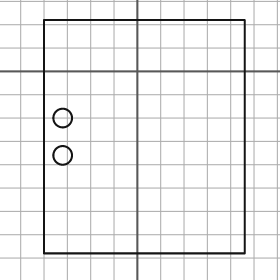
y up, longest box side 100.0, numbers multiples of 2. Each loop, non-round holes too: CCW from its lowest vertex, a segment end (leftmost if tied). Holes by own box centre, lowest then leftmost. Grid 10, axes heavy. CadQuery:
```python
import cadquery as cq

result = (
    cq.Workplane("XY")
    .moveTo(-40.0, -78.0)
    .lineTo(46.0, -78.0)
    .lineTo(46.0, 22.0)
    .lineTo(-40.0, 22.0)
    .close()
    .moveTo(-32.0, -36.0)
    .circle(4.0)
    .moveTo(-32.0, -20.0)
    .circle(4.0)
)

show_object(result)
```